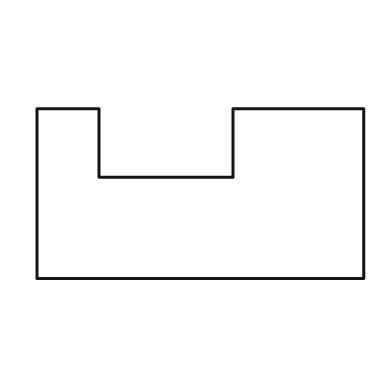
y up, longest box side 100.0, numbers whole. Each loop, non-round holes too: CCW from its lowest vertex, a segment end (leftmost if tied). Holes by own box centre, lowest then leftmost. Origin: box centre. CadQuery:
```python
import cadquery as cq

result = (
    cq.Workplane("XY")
    .moveTo(-50.0, -26.0)
    .lineTo(50.0, -26.0)
    .lineTo(50.0, 26.0)
    .lineTo(10.0, 26.0)
    .lineTo(10.0, 5.0)
    .lineTo(-31.0, 5.0)
    .lineTo(-31.0, 26.0)
    .lineTo(-50.0, 26.0)
    .close()
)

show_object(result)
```